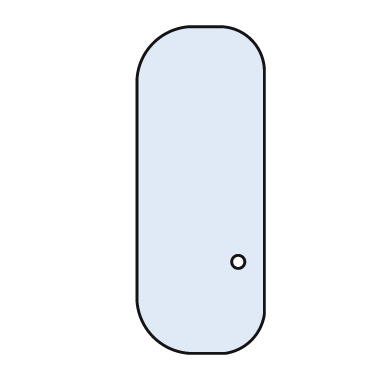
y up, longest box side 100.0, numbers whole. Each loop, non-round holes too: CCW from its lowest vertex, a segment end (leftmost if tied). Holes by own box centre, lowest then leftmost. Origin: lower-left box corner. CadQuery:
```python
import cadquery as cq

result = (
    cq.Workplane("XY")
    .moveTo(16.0, 0.0)
    .lineTo(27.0, 0.0)
    .threePointArc((35.0, 4.0), (39.0, 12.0))
    .lineTo(39.0, 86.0)
    .threePointArc((35.0, 96.0), (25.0, 100.0))
    .lineTo(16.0, 100.0)
    .threePointArc((5.0, 95.0), (0.0, 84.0))
    .lineTo(0.0, 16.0)
    .threePointArc((5.0, 5.0), (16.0, 0.0))
    .close()
    .moveTo(31.0, 28.0)
    .circle(2.0)
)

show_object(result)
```